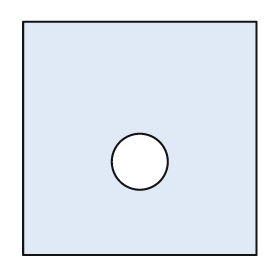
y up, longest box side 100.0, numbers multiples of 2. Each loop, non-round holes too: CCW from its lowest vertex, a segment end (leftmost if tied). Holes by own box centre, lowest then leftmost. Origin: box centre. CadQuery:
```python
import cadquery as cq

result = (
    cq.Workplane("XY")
    .moveTo(-50.0, -50.0)
    .lineTo(50.0, -50.0)
    .lineTo(50.0, 50.0)
    .lineTo(-50.0, 50.0)
    .close()
    .moveTo(0.0, -10.0)
    .circle(12.0)
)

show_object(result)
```